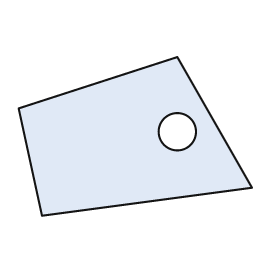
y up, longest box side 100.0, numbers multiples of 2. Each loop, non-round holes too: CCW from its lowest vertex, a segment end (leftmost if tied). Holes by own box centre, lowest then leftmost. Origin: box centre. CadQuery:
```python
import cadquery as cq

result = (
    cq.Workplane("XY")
    .moveTo(-40.0, -34.0)
    .lineTo(50.0, -22.0)
    .lineTo(18.0, 34.0)
    .lineTo(-50.0, 12.0)
    .close()
    .moveTo(18.0, 2.0)
    .circle(8.0)
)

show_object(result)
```